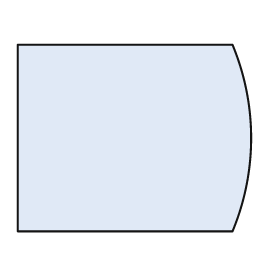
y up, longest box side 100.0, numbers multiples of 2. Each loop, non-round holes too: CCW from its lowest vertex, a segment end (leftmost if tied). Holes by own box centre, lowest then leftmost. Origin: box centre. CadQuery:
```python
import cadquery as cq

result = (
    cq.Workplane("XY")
    .moveTo(-50.0, -40.0)
    .lineTo(42.0, -40.0)
    .threePointArc((50.0, 0.0), (42.0, 40.0))
    .lineTo(-50.0, 40.0)
    .close()
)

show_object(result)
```